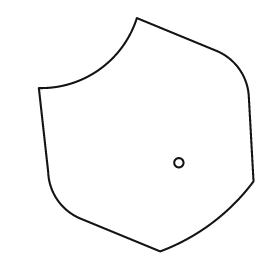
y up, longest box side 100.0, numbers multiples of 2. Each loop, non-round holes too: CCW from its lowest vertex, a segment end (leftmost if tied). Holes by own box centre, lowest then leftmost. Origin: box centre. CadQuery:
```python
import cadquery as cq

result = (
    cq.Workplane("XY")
    .moveTo(6.0, -50.0)
    .threePointArc((28.0, -38.0), (46.0, -20.0))
    .lineTo(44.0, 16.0)
    .threePointArc((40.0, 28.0), (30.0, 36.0))
    .lineTo(-4.0, 50.0)
    .threePointArc((-20.0, 28.0), (-46.0, 20.0))
    .lineTo(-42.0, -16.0)
    .threePointArc((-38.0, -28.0), (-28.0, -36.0))
    .close()
    .moveTo(14.0, -12.0)
    .circle(2.0)
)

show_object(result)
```